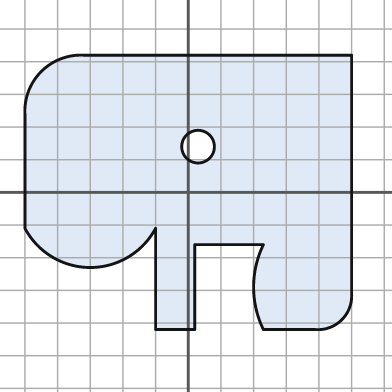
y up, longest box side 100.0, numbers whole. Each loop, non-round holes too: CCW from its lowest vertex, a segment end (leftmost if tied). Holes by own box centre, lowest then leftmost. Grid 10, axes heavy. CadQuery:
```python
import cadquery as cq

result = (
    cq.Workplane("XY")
    .moveTo(-10.0, -42.0)
    .lineTo(2.0, -42.0)
    .lineTo(2.0, -16.0)
    .lineTo(23.0, -16.0)
    .threePointArc((20.0, -29.0), (23.0, -42.0))
    .lineTo(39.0, -42.0)
    .threePointArc((47.0, -39.0), (50.0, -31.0))
    .lineTo(50.0, 42.0)
    .lineTo(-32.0, 42.0)
    .threePointArc((-45.0, 37.0), (-50.0, 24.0))
    .lineTo(-50.0, -11.0)
    .threePointArc((-30.0, -23.0), (-10.0, -11.0))
    .close()
    .moveTo(3.0, 14.0)
    .circle(5.0)
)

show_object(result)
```